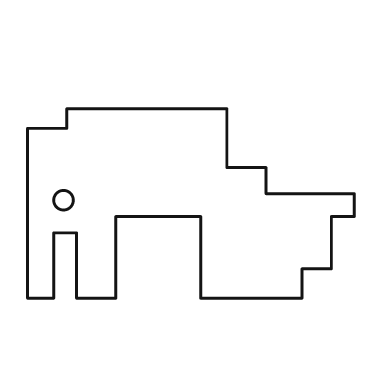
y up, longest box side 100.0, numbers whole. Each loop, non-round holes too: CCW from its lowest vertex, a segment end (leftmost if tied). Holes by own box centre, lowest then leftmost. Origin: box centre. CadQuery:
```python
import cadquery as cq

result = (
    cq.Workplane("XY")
    .moveTo(-50.0, -29.0)
    .lineTo(-42.0, -29.0)
    .lineTo(-42.0, -9.0)
    .lineTo(-35.0, -9.0)
    .lineTo(-35.0, -29.0)
    .lineTo(-23.0, -29.0)
    .lineTo(-23.0, -4.0)
    .lineTo(3.0, -4.0)
    .lineTo(3.0, -29.0)
    .lineTo(34.0, -29.0)
    .lineTo(34.0, -20.0)
    .lineTo(43.0, -20.0)
    .lineTo(43.0, -4.0)
    .lineTo(50.0, -4.0)
    .lineTo(50.0, 3.0)
    .lineTo(23.0, 3.0)
    .lineTo(23.0, 11.0)
    .lineTo(11.0, 11.0)
    .lineTo(11.0, 29.0)
    .lineTo(-38.0, 29.0)
    .lineTo(-38.0, 23.0)
    .lineTo(-50.0, 23.0)
    .close()
    .moveTo(-39.0, 1.0)
    .circle(3.0)
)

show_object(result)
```